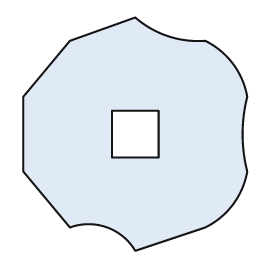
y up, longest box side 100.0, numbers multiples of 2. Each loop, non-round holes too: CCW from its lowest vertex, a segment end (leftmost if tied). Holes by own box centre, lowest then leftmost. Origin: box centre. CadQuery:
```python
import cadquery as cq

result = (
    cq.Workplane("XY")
    .moveTo(0.0, -50.0)
    .lineTo(30.0, -40.0)
    .threePointArc((42.0, -30.0), (48.0, -16.0))
    .threePointArc((46.0, 0.0), (48.0, 16.0))
    .threePointArc((42.0, 30.0), (30.0, 40.0))
    .threePointArc((14.0, 42.0), (0.0, 50.0))
    .lineTo(-28.0, 40.0)
    .lineTo(-48.0, 16.0)
    .lineTo(-48.0, -16.0)
    .lineTo(-28.0, -40.0)
    .threePointArc((-12.0, -40.0), (0.0, -50.0))
    .close()
    .moveTo(-10.0, -10.0)
    .lineTo(10.0, -10.0)
    .lineTo(10.0, 10.0)
    .lineTo(-10.0, 10.0)
    .close()
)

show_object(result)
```